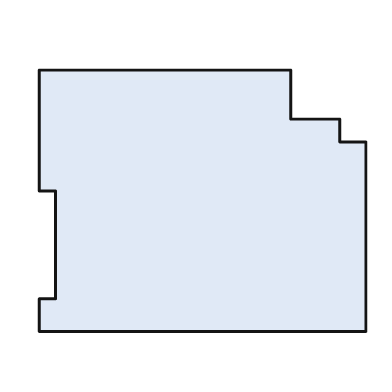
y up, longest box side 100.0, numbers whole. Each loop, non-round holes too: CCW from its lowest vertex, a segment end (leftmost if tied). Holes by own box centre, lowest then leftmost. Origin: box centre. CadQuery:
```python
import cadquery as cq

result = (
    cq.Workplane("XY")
    .moveTo(-50.0, -40.0)
    .lineTo(50.0, -40.0)
    .lineTo(50.0, 18.0)
    .lineTo(42.0, 18.0)
    .lineTo(42.0, 25.0)
    .lineTo(27.0, 25.0)
    .lineTo(27.0, 40.0)
    .lineTo(-50.0, 40.0)
    .lineTo(-50.0, 3.0)
    .lineTo(-45.0, 3.0)
    .lineTo(-45.0, -30.0)
    .lineTo(-50.0, -30.0)
    .close()
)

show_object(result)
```